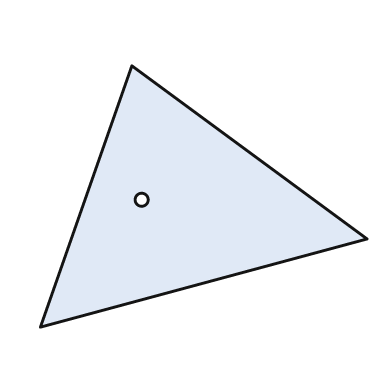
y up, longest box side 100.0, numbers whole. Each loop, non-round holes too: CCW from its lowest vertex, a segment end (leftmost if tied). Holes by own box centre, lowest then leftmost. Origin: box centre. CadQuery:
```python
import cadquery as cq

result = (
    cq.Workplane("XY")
    .moveTo(-50.0, -40.0)
    .lineTo(50.0, -13.0)
    .lineTo(-22.0, 40.0)
    .close()
    .moveTo(-19.0, -1.0)
    .circle(2.0)
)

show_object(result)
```